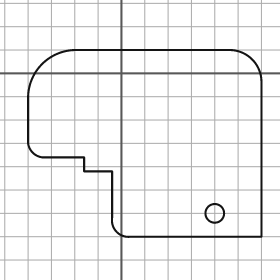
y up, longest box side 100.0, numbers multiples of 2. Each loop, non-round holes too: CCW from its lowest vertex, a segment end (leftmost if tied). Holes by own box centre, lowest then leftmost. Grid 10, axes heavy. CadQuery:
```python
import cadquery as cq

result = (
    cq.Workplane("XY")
    .moveTo(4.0, -70.0)
    .lineTo(60.0, -70.0)
    .lineTo(60.0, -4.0)
    .threePointArc((56.0, 6.0), (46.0, 10.0))
    .lineTo(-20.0, 10.0)
    .threePointArc((-34.0, 4.0), (-40.0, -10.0))
    .lineTo(-40.0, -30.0)
    .threePointArc((-38.0, -34.0), (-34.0, -36.0))
    .lineTo(-16.0, -36.0)
    .lineTo(-16.0, -42.0)
    .lineTo(-4.0, -42.0)
    .lineTo(-4.0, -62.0)
    .threePointArc((-2.0, -68.0), (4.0, -70.0))
    .close()
    .moveTo(40.0, -60.0)
    .circle(4.0)
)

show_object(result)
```